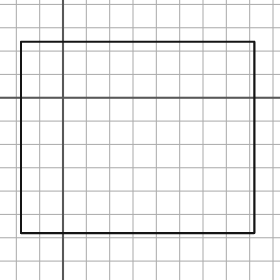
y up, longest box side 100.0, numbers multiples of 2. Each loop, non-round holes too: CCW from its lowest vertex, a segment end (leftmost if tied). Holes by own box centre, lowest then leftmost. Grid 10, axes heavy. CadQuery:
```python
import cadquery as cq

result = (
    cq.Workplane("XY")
    .moveTo(-18.0, -58.0)
    .lineTo(82.0, -58.0)
    .lineTo(82.0, 24.0)
    .lineTo(-18.0, 24.0)
    .close()
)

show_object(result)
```